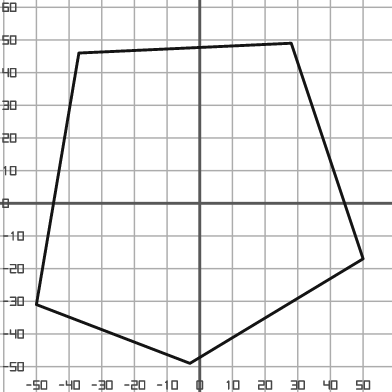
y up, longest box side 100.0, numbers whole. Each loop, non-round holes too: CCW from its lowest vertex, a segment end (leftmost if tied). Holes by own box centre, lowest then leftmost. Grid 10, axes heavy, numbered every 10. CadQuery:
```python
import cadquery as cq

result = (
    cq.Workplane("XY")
    .moveTo(-3.0, -49.0)
    .lineTo(50.0, -17.0)
    .lineTo(28.0, 49.0)
    .lineTo(-37.0, 46.0)
    .lineTo(-50.0, -31.0)
    .close()
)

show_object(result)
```